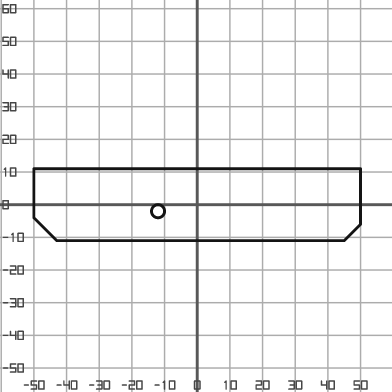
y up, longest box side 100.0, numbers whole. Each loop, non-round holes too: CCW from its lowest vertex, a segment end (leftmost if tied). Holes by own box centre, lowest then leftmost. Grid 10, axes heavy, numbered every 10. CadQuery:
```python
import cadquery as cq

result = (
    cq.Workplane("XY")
    .moveTo(-43.0, -11.0)
    .lineTo(45.0, -11.0)
    .lineTo(50.0, -6.0)
    .lineTo(50.0, 11.0)
    .lineTo(-50.0, 11.0)
    .lineTo(-50.0, -4.0)
    .close()
    .moveTo(-12.0, -2.0)
    .circle(2.0)
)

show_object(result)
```